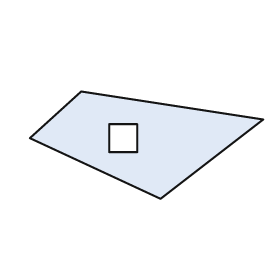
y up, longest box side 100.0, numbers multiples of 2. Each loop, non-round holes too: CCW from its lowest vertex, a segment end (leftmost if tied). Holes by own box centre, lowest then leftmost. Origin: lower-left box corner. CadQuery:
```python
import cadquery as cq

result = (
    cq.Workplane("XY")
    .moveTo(56.0, 0.0)
    .lineTo(100.0, 34.0)
    .lineTo(22.0, 46.0)
    .lineTo(0.0, 26.0)
    .close()
    .moveTo(34.0, 20.0)
    .lineTo(46.0, 20.0)
    .lineTo(46.0, 32.0)
    .lineTo(34.0, 32.0)
    .close()
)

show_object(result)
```